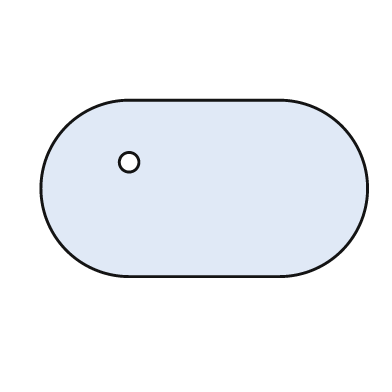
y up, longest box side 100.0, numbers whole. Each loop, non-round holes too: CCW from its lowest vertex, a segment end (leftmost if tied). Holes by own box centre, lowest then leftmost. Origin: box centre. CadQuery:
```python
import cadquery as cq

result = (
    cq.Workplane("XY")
    .moveTo(-23.0, -27.0)
    .lineTo(23.0, -27.0)
    .threePointArc((50.0, 0.0), (23.0, 27.0))
    .lineTo(-23.0, 27.0)
    .threePointArc((-50.0, 0.0), (-23.0, -27.0))
    .close()
    .moveTo(-23.0, 8.0)
    .circle(3.0)
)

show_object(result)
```